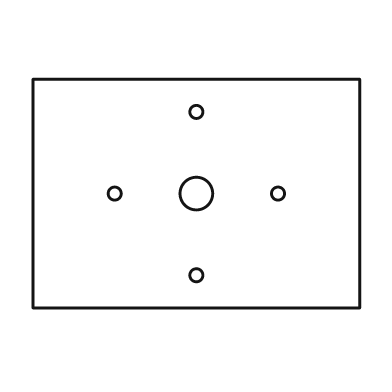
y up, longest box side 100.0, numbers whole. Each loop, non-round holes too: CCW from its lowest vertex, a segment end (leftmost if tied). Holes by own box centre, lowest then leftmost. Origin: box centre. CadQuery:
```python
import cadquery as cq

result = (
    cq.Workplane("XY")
    .moveTo(-50.0, -35.0)
    .lineTo(50.0, -35.0)
    .lineTo(50.0, 35.0)
    .lineTo(-50.0, 35.0)
    .close()
    .moveTo(0.0, -25.0)
    .circle(2.0)
    .moveTo(-25.0, 0.0)
    .circle(2.0)
    .moveTo(0.0, 0.0)
    .circle(5.0)
    .moveTo(25.0, 0.0)
    .circle(2.0)
    .moveTo(0.0, 25.0)
    .circle(2.0)
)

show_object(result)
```